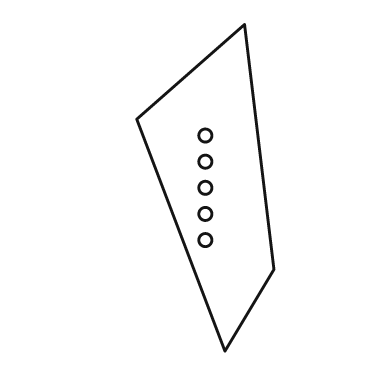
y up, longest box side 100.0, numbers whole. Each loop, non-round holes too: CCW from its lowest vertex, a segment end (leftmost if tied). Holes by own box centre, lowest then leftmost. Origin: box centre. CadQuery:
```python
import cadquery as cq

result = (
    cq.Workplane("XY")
    .moveTo(6.0, -50.0)
    .lineTo(21.0, -25.0)
    .lineTo(12.0, 50.0)
    .lineTo(-21.0, 21.0)
    .close()
    .moveTo(0.0, -16.0)
    .circle(2.0)
    .moveTo(0.0, -8.0)
    .circle(2.0)
    .moveTo(0.0, 0.0)
    .circle(2.0)
    .moveTo(0.0, 8.0)
    .circle(2.0)
    .moveTo(0.0, 16.0)
    .circle(2.0)
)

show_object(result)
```